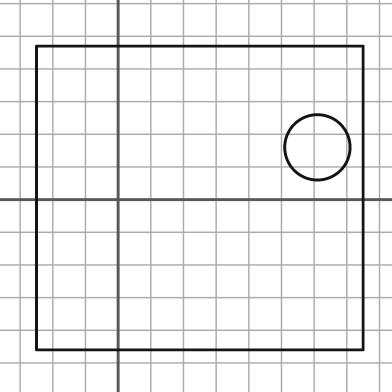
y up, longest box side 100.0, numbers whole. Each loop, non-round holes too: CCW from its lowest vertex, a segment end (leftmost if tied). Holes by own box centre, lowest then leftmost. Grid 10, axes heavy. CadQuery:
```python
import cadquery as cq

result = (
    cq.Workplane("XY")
    .moveTo(-25.0, -46.0)
    .lineTo(75.0, -46.0)
    .lineTo(75.0, 47.0)
    .lineTo(-25.0, 47.0)
    .close()
    .moveTo(61.0, 16.0)
    .circle(10.0)
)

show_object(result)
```